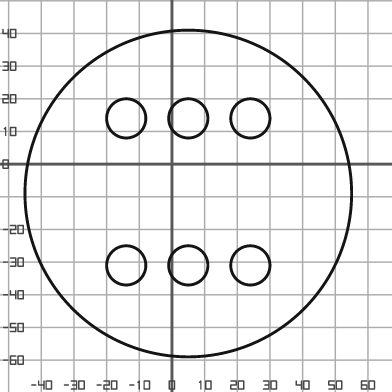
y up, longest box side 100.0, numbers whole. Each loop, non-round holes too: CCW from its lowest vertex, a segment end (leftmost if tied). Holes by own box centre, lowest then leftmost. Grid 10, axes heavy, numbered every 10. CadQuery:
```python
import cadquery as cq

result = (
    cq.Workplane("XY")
    .moveTo(5.0, -9.0)
    .circle(50.0)
    .moveTo(-14.0, -31.0)
    .circle(6.0)
    .moveTo(5.0, -31.0)
    .circle(6.0)
    .moveTo(24.0, -31.0)
    .circle(6.0)
    .moveTo(-14.0, 14.0)
    .circle(6.0)
    .moveTo(5.0, 14.0)
    .circle(6.0)
    .moveTo(24.0, 14.0)
    .circle(6.0)
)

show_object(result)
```